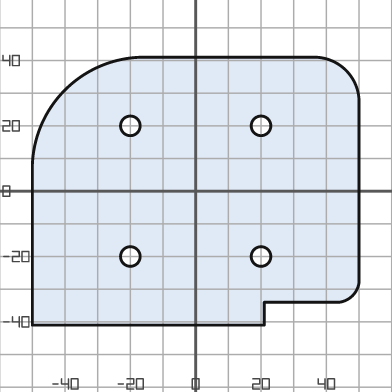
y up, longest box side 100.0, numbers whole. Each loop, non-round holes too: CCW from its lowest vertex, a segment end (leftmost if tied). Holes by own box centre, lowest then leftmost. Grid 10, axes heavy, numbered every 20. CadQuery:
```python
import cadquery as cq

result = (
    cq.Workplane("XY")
    .moveTo(-50.0, -41.0)
    .lineTo(21.0, -41.0)
    .lineTo(21.0, -34.0)
    .lineTo(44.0, -34.0)
    .threePointArc((48.0, -32.0), (50.0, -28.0))
    .lineTo(50.0, 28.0)
    .threePointArc((46.0, 37.0), (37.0, 41.0))
    .lineTo(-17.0, 41.0)
    .threePointArc((-40.0, 31.0), (-50.0, 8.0))
    .close()
    .moveTo(-20.0, -20.0)
    .circle(3.0)
    .moveTo(20.0, -20.0)
    .circle(3.0)
    .moveTo(-20.0, 20.0)
    .circle(3.0)
    .moveTo(20.0, 20.0)
    .circle(3.0)
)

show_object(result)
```